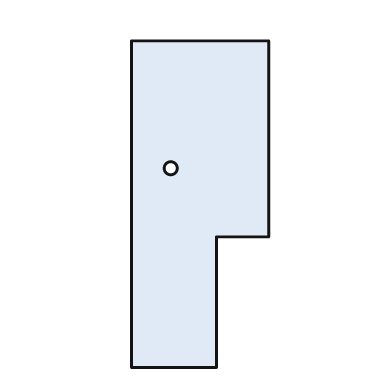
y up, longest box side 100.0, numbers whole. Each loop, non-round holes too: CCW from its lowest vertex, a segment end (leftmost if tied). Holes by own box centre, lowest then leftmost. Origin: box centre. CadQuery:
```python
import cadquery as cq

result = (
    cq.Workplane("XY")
    .moveTo(-21.0, -50.0)
    .lineTo(5.0, -50.0)
    .lineTo(5.0, -10.0)
    .lineTo(21.0, -10.0)
    .lineTo(21.0, 50.0)
    .lineTo(-21.0, 50.0)
    .close()
    .moveTo(-9.0, 11.0)
    .circle(2.0)
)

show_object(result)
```